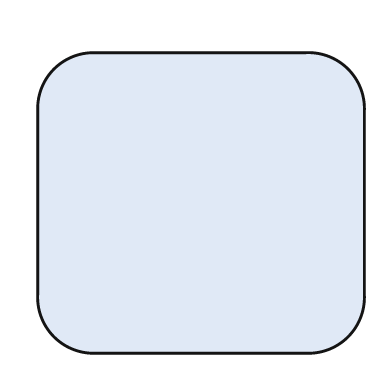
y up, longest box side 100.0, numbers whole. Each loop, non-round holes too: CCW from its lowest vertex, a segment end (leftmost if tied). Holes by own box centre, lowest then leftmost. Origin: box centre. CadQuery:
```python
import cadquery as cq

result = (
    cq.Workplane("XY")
    .moveTo(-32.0, -46.0)
    .lineTo(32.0, -46.0)
    .threePointArc((45.0, -41.0), (50.0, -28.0))
    .lineTo(50.0, 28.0)
    .threePointArc((45.0, 41.0), (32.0, 46.0))
    .lineTo(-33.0, 46.0)
    .threePointArc((-45.0, 41.0), (-50.0, 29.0))
    .lineTo(-50.0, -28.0)
    .threePointArc((-45.0, -41.0), (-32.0, -46.0))
    .close()
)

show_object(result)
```